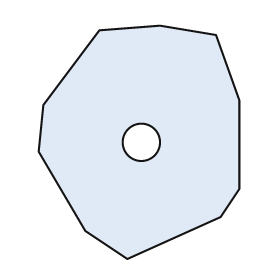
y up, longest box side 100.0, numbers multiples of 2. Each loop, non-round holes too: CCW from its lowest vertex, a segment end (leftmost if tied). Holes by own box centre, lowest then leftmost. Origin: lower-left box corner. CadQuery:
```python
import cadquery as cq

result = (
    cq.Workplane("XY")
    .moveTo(38.0, 0.0)
    .lineTo(78.0, 18.0)
    .lineTo(86.0, 30.0)
    .lineTo(86.0, 68.0)
    .lineTo(76.0, 96.0)
    .lineTo(52.0, 100.0)
    .lineTo(26.0, 98.0)
    .lineTo(2.0, 66.0)
    .lineTo(0.0, 46.0)
    .lineTo(20.0, 12.0)
    .close()
    .moveTo(44.0, 50.0)
    .circle(8.0)
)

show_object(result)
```